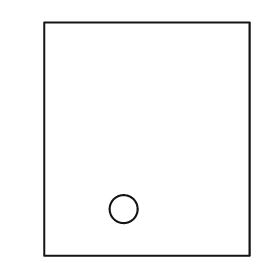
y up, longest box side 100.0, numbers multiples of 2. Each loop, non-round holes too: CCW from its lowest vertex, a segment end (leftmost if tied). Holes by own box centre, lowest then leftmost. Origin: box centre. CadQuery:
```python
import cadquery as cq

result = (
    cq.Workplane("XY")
    .moveTo(-44.0, -50.0)
    .lineTo(44.0, -50.0)
    .lineTo(44.0, 50.0)
    .lineTo(-44.0, 50.0)
    .close()
    .moveTo(-10.0, -30.0)
    .circle(6.0)
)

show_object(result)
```